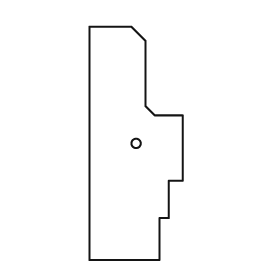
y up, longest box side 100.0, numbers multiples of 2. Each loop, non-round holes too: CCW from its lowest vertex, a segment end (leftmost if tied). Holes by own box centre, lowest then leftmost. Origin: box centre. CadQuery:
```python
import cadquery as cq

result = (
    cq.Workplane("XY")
    .moveTo(-20.0, -50.0)
    .lineTo(10.0, -50.0)
    .lineTo(10.0, -32.0)
    .lineTo(14.0, -32.0)
    .lineTo(14.0, -16.0)
    .lineTo(20.0, -16.0)
    .lineTo(20.0, 12.0)
    .lineTo(8.0, 12.0)
    .lineTo(4.0, 16.0)
    .lineTo(4.0, 44.0)
    .lineTo(-2.0, 50.0)
    .lineTo(-20.0, 50.0)
    .close()
    .moveTo(0.0, 0.0)
    .circle(2.0)
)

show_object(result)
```